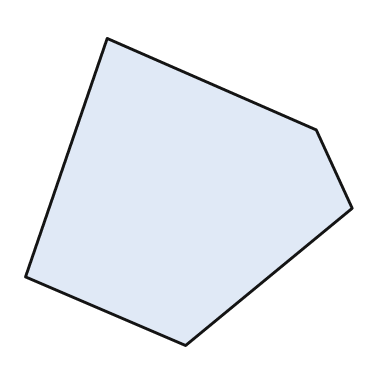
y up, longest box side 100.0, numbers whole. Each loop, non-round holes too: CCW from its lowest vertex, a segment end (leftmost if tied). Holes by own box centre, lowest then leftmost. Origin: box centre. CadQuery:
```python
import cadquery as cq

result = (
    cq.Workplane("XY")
    .moveTo(-1.0, -47.0)
    .lineTo(50.0, -5.0)
    .lineTo(39.0, 19.0)
    .lineTo(-25.0, 47.0)
    .lineTo(-50.0, -26.0)
    .close()
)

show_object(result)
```